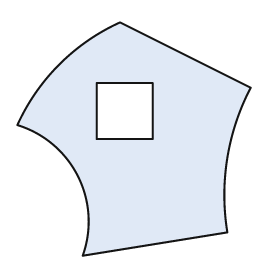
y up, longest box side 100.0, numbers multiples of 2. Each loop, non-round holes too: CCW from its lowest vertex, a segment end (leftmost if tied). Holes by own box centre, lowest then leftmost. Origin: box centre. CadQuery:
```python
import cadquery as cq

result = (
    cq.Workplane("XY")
    .moveTo(-22.0, -50.0)
    .lineTo(40.0, -40.0)
    .threePointArc((40.0, -8.0), (50.0, 22.0))
    .lineTo(-6.0, 50.0)
    .threePointArc((-32.0, 32.0), (-50.0, 6.0))
    .threePointArc((-24.0, -16.0), (-22.0, -50.0))
    .close()
    .moveTo(-16.0, 0.0)
    .lineTo(8.0, 0.0)
    .lineTo(8.0, 24.0)
    .lineTo(-16.0, 24.0)
    .close()
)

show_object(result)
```